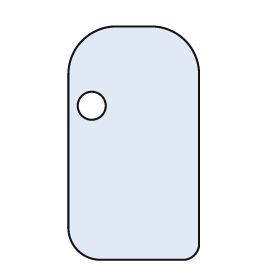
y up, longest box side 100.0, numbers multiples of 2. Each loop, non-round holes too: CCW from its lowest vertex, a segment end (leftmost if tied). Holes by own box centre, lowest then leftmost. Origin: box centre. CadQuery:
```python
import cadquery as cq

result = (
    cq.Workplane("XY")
    .moveTo(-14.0, -50.0)
    .lineTo(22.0, -50.0)
    .threePointArc((26.0, -48.0), (28.0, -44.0))
    .lineTo(28.0, 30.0)
    .threePointArc((22.0, 44.0), (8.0, 50.0))
    .lineTo(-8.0, 50.0)
    .threePointArc((-22.0, 44.0), (-28.0, 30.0))
    .lineTo(-28.0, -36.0)
    .threePointArc((-24.0, -46.0), (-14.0, -50.0))
    .close()
    .moveTo(-18.0, 16.0)
    .circle(6.0)
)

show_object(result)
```